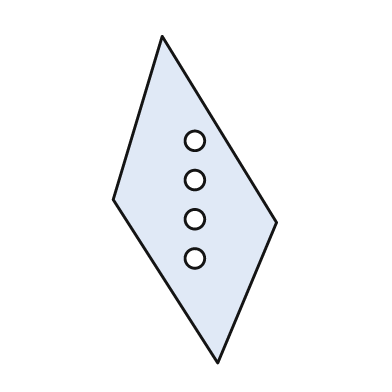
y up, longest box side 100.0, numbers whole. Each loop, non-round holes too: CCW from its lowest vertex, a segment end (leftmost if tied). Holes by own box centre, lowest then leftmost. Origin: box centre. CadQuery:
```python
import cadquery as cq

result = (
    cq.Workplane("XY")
    .moveTo(7.0, -50.0)
    .lineTo(25.0, -7.0)
    .lineTo(-10.0, 50.0)
    .lineTo(-25.0, 0.0)
    .close()
    .moveTo(0.0, -18.0)
    .circle(3.0)
    .moveTo(0.0, -6.0)
    .circle(3.0)
    .moveTo(0.0, 6.0)
    .circle(3.0)
    .moveTo(0.0, 18.0)
    .circle(3.0)
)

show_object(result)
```